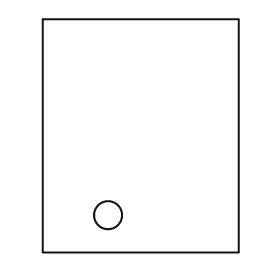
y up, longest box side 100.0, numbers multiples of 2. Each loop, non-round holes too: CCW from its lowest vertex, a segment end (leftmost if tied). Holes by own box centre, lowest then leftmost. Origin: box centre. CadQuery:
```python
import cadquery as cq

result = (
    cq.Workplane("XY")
    .moveTo(-42.0, -50.0)
    .lineTo(42.0, -50.0)
    .lineTo(42.0, 50.0)
    .lineTo(-42.0, 50.0)
    .close()
    .moveTo(-14.0, -34.0)
    .circle(6.0)
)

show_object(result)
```